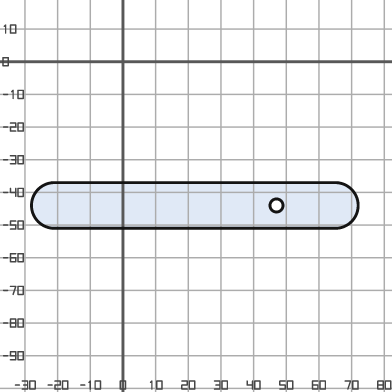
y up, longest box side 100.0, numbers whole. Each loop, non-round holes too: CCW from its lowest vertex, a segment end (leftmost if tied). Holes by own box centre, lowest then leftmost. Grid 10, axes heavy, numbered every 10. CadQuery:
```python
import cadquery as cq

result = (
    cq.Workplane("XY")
    .moveTo(-21.0, -51.0)
    .lineTo(65.0, -51.0)
    .threePointArc((72.0, -44.0), (65.0, -37.0))
    .lineTo(-21.0, -37.0)
    .threePointArc((-28.0, -44.0), (-21.0, -51.0))
    .close()
    .moveTo(47.0, -44.0)
    .circle(2.0)
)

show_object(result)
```